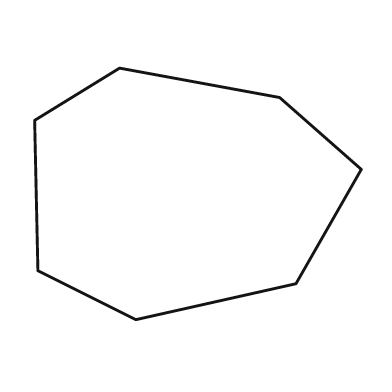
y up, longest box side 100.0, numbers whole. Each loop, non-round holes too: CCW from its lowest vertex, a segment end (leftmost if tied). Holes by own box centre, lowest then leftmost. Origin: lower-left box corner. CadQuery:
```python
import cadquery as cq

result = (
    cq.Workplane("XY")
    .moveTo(31.0, 0.0)
    .lineTo(80.0, 11.0)
    .lineTo(100.0, 46.0)
    .lineTo(75.0, 68.0)
    .lineTo(26.0, 77.0)
    .lineTo(0.0, 61.0)
    .lineTo(1.0, 15.0)
    .close()
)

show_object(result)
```